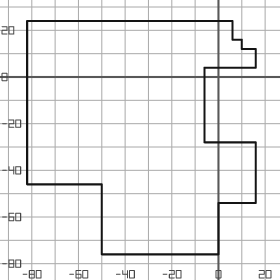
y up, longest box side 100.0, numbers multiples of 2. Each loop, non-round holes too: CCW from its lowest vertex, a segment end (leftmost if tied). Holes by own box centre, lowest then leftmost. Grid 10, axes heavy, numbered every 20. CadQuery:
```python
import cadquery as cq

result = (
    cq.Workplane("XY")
    .moveTo(-50.0, -76.0)
    .lineTo(0.0, -76.0)
    .lineTo(0.0, -54.0)
    .lineTo(16.0, -54.0)
    .lineTo(16.0, -28.0)
    .lineTo(-6.0, -28.0)
    .lineTo(-6.0, 4.0)
    .lineTo(16.0, 4.0)
    .lineTo(16.0, 12.0)
    .lineTo(10.0, 12.0)
    .lineTo(10.0, 16.0)
    .lineTo(6.0, 16.0)
    .lineTo(6.0, 24.0)
    .lineTo(-82.0, 24.0)
    .lineTo(-82.0, -46.0)
    .lineTo(-50.0, -46.0)
    .close()
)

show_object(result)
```